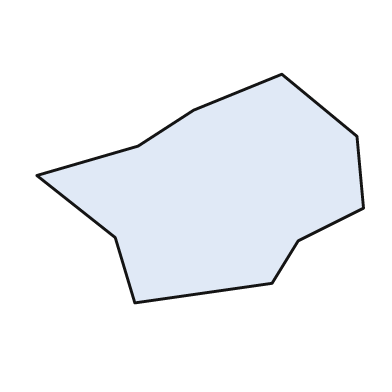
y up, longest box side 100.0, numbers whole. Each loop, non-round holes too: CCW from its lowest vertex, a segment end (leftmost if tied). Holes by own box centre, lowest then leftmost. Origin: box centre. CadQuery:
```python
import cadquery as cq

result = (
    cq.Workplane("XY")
    .moveTo(-20.0, -35.0)
    .lineTo(22.0, -29.0)
    .lineTo(30.0, -16.0)
    .lineTo(50.0, -6.0)
    .lineTo(48.0, 16.0)
    .lineTo(25.0, 35.0)
    .lineTo(-2.0, 24.0)
    .lineTo(-19.0, 13.0)
    .lineTo(-50.0, 4.0)
    .lineTo(-26.0, -15.0)
    .close()
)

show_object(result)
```